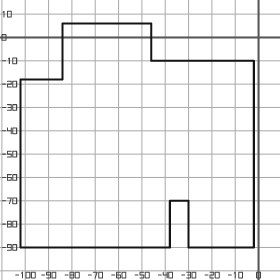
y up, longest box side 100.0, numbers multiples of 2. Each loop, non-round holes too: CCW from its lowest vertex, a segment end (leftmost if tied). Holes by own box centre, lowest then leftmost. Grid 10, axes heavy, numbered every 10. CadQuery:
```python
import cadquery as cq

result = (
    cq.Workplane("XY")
    .moveTo(-102.0, -90.0)
    .lineTo(-38.0, -90.0)
    .lineTo(-38.0, -70.0)
    .lineTo(-30.0, -70.0)
    .lineTo(-30.0, -90.0)
    .lineTo(-2.0, -90.0)
    .lineTo(-2.0, -10.0)
    .lineTo(-46.0, -10.0)
    .lineTo(-46.0, 6.0)
    .lineTo(-84.0, 6.0)
    .lineTo(-84.0, -18.0)
    .lineTo(-102.0, -18.0)
    .close()
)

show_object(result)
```